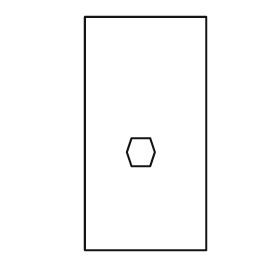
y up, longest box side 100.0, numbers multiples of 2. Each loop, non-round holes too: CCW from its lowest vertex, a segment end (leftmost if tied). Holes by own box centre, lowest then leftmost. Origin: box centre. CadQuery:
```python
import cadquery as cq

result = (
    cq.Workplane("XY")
    .moveTo(-26.0, -50.0)
    .lineTo(26.0, -50.0)
    .lineTo(26.0, 50.0)
    .lineTo(-26.0, 50.0)
    .close()
    .moveTo(-6.0, -14.0)
    .lineTo(2.0, -14.0)
    .lineTo(4.0, -8.0)
    .lineTo(2.0, -2.0)
    .lineTo(-6.0, -2.0)
    .lineTo(-8.0, -8.0)
    .close()
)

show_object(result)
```